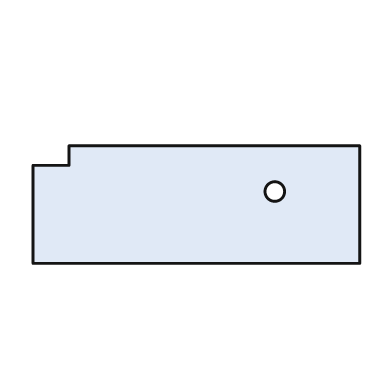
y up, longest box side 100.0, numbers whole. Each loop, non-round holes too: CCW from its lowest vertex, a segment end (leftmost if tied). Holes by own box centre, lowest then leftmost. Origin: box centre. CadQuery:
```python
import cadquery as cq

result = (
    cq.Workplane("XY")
    .moveTo(-50.0, -18.0)
    .lineTo(50.0, -18.0)
    .lineTo(50.0, 18.0)
    .lineTo(-39.0, 18.0)
    .lineTo(-39.0, 12.0)
    .lineTo(-50.0, 12.0)
    .close()
    .moveTo(24.0, 4.0)
    .circle(3.0)
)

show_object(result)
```